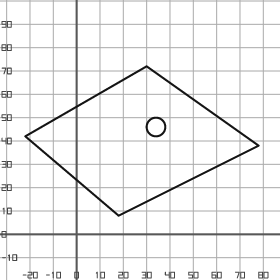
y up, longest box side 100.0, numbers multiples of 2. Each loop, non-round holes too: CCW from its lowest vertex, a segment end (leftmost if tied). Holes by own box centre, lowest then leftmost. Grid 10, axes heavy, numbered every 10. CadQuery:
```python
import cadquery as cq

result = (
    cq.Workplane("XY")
    .moveTo(18.0, 8.0)
    .lineTo(78.0, 38.0)
    .lineTo(30.0, 72.0)
    .lineTo(-22.0, 42.0)
    .close()
    .moveTo(34.0, 46.0)
    .circle(4.0)
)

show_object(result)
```